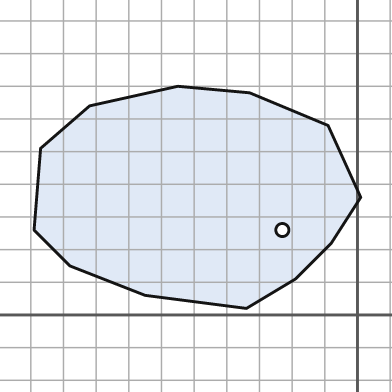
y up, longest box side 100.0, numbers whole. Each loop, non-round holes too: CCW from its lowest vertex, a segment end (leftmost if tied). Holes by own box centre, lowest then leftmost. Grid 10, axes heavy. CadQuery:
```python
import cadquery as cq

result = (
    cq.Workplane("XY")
    .moveTo(-34.0, 2.0)
    .lineTo(-19.0, 11.0)
    .lineTo(-8.0, 22.0)
    .lineTo(1.0, 36.0)
    .lineTo(-9.0, 58.0)
    .lineTo(-33.0, 68.0)
    .lineTo(-55.0, 70.0)
    .lineTo(-82.0, 64.0)
    .lineTo(-97.0, 51.0)
    .lineTo(-99.0, 26.0)
    .lineTo(-88.0, 15.0)
    .lineTo(-65.0, 6.0)
    .close()
    .moveTo(-23.0, 26.0)
    .circle(2.0)
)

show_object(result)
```